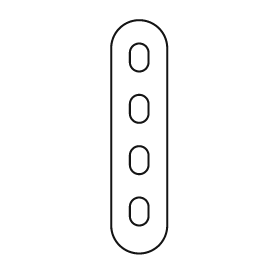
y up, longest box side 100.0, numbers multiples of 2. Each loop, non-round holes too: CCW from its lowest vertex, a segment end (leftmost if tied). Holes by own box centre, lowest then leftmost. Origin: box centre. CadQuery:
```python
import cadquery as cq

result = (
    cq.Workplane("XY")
    .moveTo(-12.0, -38.0)
    .threePointArc((0.0, -50.0), (12.0, -38.0))
    .lineTo(12.0, 38.0)
    .threePointArc((0.0, 50.0), (-12.0, 38.0))
    .close()
    .moveTo(-4.0, -34.0)
    .threePointArc((0.0, -38.0), (4.0, -34.0))
    .lineTo(4.0, -30.0)
    .threePointArc((0.0, -26.0), (-4.0, -30.0))
    .close()
    .moveTo(-4.0, -12.0)
    .threePointArc((0.0, -16.0), (4.0, -12.0))
    .lineTo(4.0, -8.0)
    .threePointArc((0.0, -4.0), (-4.0, -8.0))
    .close()
    .moveTo(-4.0, 10.0)
    .threePointArc((0.0, 6.0), (4.0, 10.0))
    .lineTo(4.0, 14.0)
    .threePointArc((0.0, 18.0), (-4.0, 14.0))
    .close()
    .moveTo(-4.0, 32.0)
    .threePointArc((0.0, 28.0), (4.0, 32.0))
    .lineTo(4.0, 36.0)
    .threePointArc((0.0, 40.0), (-4.0, 36.0))
    .close()
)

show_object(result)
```